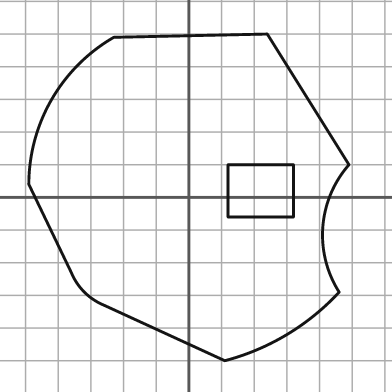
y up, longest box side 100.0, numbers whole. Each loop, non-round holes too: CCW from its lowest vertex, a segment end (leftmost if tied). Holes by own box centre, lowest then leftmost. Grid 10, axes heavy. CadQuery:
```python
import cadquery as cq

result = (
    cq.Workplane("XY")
    .moveTo(11.0, -50.0)
    .threePointArc((30.0, -42.0), (46.0, -29.0))
    .threePointArc((41.0, -9.0), (49.0, 10.0))
    .lineTo(24.0, 50.0)
    .lineTo(-23.0, 49.0)
    .threePointArc((-42.0, 30.0), (-49.0, 4.0))
    .lineTo(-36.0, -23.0)
    .threePointArc((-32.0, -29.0), (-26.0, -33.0))
    .close()
    .moveTo(12.0, -6.0)
    .lineTo(32.0, -6.0)
    .lineTo(32.0, 10.0)
    .lineTo(12.0, 10.0)
    .close()
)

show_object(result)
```